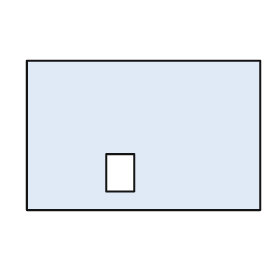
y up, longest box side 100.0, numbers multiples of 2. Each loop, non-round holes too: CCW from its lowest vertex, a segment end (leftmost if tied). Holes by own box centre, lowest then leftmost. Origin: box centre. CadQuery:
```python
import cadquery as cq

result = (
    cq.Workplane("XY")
    .moveTo(-50.0, -32.0)
    .lineTo(50.0, -32.0)
    .lineTo(50.0, 32.0)
    .lineTo(-50.0, 32.0)
    .close()
    .moveTo(-16.0, -24.0)
    .lineTo(-4.0, -24.0)
    .lineTo(-4.0, -8.0)
    .lineTo(-16.0, -8.0)
    .close()
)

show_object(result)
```